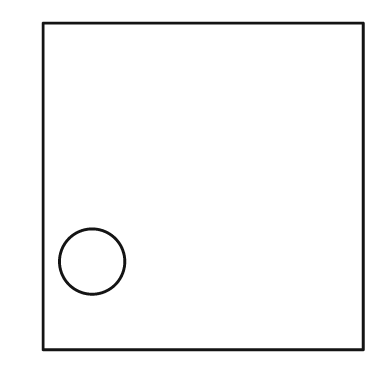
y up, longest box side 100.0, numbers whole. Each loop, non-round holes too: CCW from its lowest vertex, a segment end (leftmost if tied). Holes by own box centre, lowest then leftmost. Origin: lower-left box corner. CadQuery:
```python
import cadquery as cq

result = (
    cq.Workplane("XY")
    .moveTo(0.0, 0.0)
    .lineTo(98.0, 0.0)
    .lineTo(98.0, 100.0)
    .lineTo(0.0, 100.0)
    .close()
    .moveTo(15.0, 27.0)
    .circle(10.0)
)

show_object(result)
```